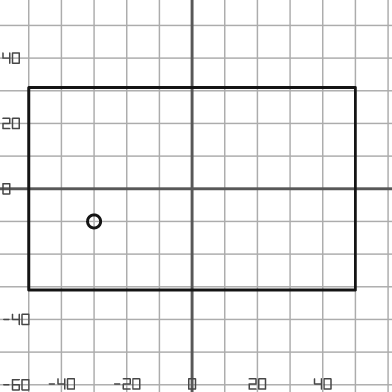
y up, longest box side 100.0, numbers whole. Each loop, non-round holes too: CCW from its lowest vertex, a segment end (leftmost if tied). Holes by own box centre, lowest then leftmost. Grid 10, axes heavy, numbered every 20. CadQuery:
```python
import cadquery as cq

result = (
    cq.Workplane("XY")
    .moveTo(-50.0, -31.0)
    .lineTo(50.0, -31.0)
    .lineTo(50.0, 31.0)
    .lineTo(-50.0, 31.0)
    .close()
    .moveTo(-30.0, -10.0)
    .circle(2.0)
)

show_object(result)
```